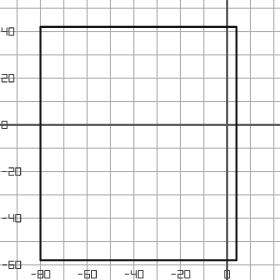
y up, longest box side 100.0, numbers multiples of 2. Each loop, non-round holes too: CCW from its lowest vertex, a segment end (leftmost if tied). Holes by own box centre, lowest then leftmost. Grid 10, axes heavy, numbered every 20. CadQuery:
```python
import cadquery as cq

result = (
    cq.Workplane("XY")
    .moveTo(-80.0, -58.0)
    .lineTo(4.0, -58.0)
    .lineTo(4.0, 42.0)
    .lineTo(-80.0, 42.0)
    .close()
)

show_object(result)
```